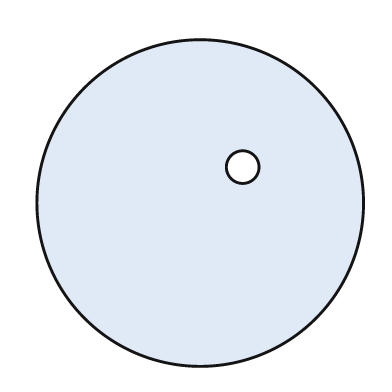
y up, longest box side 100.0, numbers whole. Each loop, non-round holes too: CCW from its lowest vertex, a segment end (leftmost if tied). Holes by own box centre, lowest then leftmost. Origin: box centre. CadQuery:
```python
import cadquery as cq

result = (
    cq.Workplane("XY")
    .moveTo(0.0, 0.0)
    .circle(50.0)
    .moveTo(13.0, 11.0)
    .circle(5.0)
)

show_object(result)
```